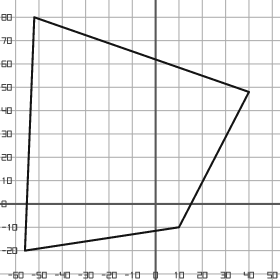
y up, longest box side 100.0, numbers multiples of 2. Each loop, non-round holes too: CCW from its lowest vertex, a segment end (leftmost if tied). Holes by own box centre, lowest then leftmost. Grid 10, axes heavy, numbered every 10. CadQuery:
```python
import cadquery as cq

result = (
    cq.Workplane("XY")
    .moveTo(-56.0, -20.0)
    .lineTo(10.0, -10.0)
    .lineTo(40.0, 48.0)
    .lineTo(-52.0, 80.0)
    .close()
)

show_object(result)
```